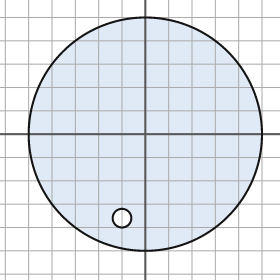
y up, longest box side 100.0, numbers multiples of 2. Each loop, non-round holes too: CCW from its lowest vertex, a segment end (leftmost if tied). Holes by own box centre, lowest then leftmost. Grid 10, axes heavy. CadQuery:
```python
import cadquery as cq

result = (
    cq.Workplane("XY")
    .moveTo(0.0, 0.0)
    .circle(50.0)
    .moveTo(-10.0, -36.0)
    .circle(4.0)
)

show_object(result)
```